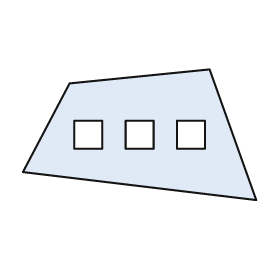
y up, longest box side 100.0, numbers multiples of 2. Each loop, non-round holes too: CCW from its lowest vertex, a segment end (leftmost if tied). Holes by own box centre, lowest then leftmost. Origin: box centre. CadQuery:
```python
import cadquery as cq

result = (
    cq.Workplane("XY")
    .moveTo(50.0, -28.0)
    .lineTo(30.0, 28.0)
    .lineTo(-30.0, 22.0)
    .lineTo(-50.0, -16.0)
    .close()
    .moveTo(-28.0, -6.0)
    .lineTo(-16.0, -6.0)
    .lineTo(-16.0, 6.0)
    .lineTo(-28.0, 6.0)
    .close()
    .moveTo(-6.0, -6.0)
    .lineTo(6.0, -6.0)
    .lineTo(6.0, 6.0)
    .lineTo(-6.0, 6.0)
    .close()
    .moveTo(16.0, -6.0)
    .lineTo(28.0, -6.0)
    .lineTo(28.0, 6.0)
    .lineTo(16.0, 6.0)
    .close()
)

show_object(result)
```